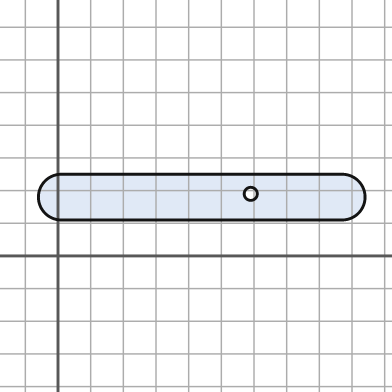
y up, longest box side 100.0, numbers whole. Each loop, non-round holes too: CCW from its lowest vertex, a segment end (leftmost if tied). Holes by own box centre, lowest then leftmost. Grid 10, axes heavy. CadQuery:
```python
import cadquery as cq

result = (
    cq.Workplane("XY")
    .moveTo(1.0, 11.0)
    .lineTo(87.0, 11.0)
    .threePointArc((94.0, 18.0), (87.0, 25.0))
    .lineTo(1.0, 25.0)
    .threePointArc((-6.0, 18.0), (1.0, 11.0))
    .close()
    .moveTo(59.0, 19.0)
    .circle(2.0)
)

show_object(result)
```